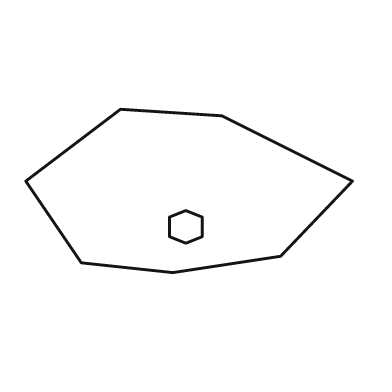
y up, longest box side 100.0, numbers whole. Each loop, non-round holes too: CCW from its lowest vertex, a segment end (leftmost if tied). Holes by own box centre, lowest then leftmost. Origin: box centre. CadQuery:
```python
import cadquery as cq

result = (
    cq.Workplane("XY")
    .moveTo(-5.0, -25.0)
    .lineTo(28.0, -20.0)
    .lineTo(50.0, 3.0)
    .lineTo(10.0, 23.0)
    .lineTo(-21.0, 25.0)
    .lineTo(-50.0, 3.0)
    .lineTo(-33.0, -22.0)
    .close()
    .moveTo(-1.0, -16.0)
    .lineTo(4.0, -14.0)
    .lineTo(4.0, -8.0)
    .lineTo(-1.0, -6.0)
    .lineTo(-6.0, -8.0)
    .lineTo(-6.0, -14.0)
    .close()
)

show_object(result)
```